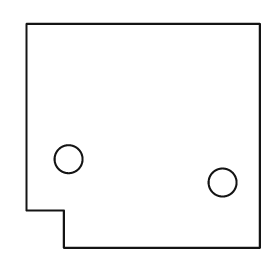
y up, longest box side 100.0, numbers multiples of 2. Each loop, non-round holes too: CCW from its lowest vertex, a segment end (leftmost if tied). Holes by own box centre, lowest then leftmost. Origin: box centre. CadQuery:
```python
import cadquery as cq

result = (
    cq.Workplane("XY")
    .moveTo(-34.0, -48.0)
    .lineTo(50.0, -48.0)
    .lineTo(50.0, 48.0)
    .lineTo(-50.0, 48.0)
    .lineTo(-50.0, -32.0)
    .lineTo(-34.0, -32.0)
    .close()
    .moveTo(34.0, -20.0)
    .circle(6.0)
    .moveTo(-32.0, -10.0)
    .circle(6.0)
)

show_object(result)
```